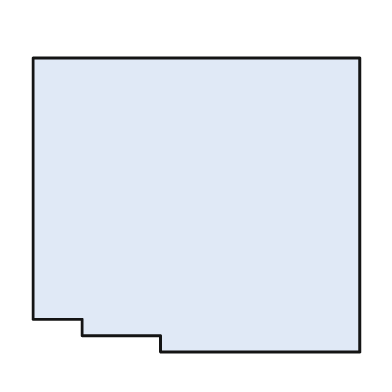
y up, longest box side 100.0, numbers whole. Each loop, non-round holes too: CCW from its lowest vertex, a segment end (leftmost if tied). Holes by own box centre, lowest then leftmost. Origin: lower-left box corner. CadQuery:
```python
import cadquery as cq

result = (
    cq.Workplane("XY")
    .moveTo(39.0, 0.0)
    .lineTo(100.0, 0.0)
    .lineTo(100.0, 90.0)
    .lineTo(0.0, 90.0)
    .lineTo(0.0, 10.0)
    .lineTo(15.0, 10.0)
    .lineTo(15.0, 5.0)
    .lineTo(39.0, 5.0)
    .close()
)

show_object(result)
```